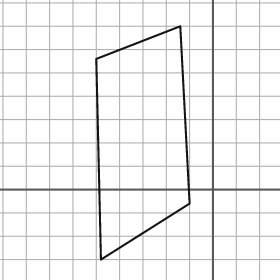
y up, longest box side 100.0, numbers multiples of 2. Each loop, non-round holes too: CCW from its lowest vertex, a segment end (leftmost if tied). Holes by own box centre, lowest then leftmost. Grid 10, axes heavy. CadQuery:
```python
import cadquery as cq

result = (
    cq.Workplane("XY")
    .moveTo(-48.0, -30.0)
    .lineTo(-10.0, -6.0)
    .lineTo(-14.0, 70.0)
    .lineTo(-50.0, 56.0)
    .close()
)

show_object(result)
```